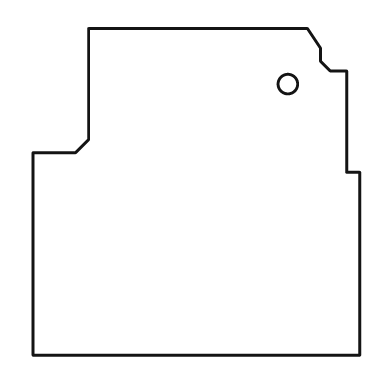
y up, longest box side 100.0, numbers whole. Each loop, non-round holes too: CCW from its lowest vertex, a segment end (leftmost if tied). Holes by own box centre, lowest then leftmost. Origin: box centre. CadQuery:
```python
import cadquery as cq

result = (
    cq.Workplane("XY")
    .moveTo(-50.0, -50.0)
    .lineTo(50.0, -50.0)
    .lineTo(50.0, 6.0)
    .lineTo(46.0, 6.0)
    .lineTo(46.0, 37.0)
    .lineTo(41.0, 37.0)
    .lineTo(38.0, 40.0)
    .lineTo(38.0, 44.0)
    .lineTo(34.0, 50.0)
    .lineTo(-33.0, 50.0)
    .lineTo(-33.0, 16.0)
    .lineTo(-37.0, 12.0)
    .lineTo(-50.0, 12.0)
    .close()
    .moveTo(28.0, 33.0)
    .circle(3.0)
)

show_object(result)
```